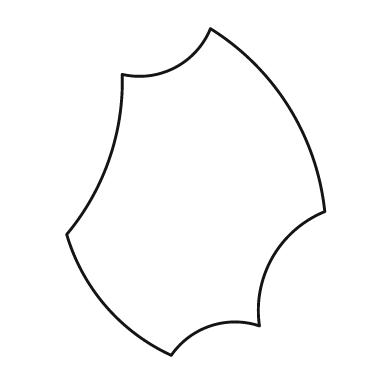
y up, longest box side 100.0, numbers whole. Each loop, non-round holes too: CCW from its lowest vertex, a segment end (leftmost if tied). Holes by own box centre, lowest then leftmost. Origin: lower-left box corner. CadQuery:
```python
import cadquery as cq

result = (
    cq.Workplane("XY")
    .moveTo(32.0, 0.0)
    .threePointArc((44.0, 9.0), (59.0, 9.0))
    .threePointArc((63.0, 30.0), (79.0, 44.0))
    .threePointArc((68.0, 76.0), (44.0, 100.0))
    .threePointArc((33.0, 88.0), (17.0, 86.0))
    .threePointArc((13.0, 60.0), (0.0, 37.0))
    .threePointArc((12.0, 15.0), (32.0, 0.0))
    .close()
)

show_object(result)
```